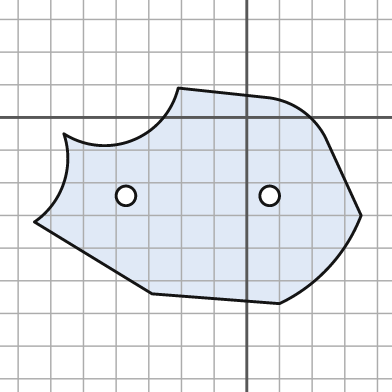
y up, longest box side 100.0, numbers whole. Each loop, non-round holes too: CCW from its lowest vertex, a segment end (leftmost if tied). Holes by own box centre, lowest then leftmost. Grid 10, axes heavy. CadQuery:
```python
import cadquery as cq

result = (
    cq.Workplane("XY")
    .moveTo(10.0, -57.0)
    .threePointArc((25.0, -46.0), (35.0, -30.0))
    .lineTo(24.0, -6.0)
    .threePointArc((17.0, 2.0), (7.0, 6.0))
    .lineTo(-21.0, 9.0)
    .threePointArc((-35.0, -7.0), (-56.0, -5.0))
    .threePointArc((-56.0, -20.0), (-65.0, -32.0))
    .lineTo(-29.0, -54.0)
    .close()
    .moveTo(-37.0, -24.0)
    .circle(3.0)
    .moveTo(7.0, -24.0)
    .circle(3.0)
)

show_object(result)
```